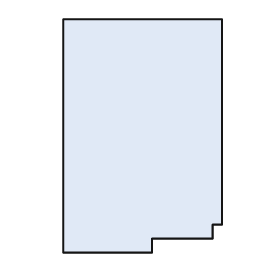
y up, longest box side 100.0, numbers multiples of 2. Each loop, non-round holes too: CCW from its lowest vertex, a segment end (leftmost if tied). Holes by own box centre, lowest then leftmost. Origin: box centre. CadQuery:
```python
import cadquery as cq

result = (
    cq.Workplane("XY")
    .moveTo(-34.0, -50.0)
    .lineTo(4.0, -50.0)
    .lineTo(4.0, -44.0)
    .lineTo(30.0, -44.0)
    .lineTo(30.0, -38.0)
    .lineTo(34.0, -38.0)
    .lineTo(34.0, 50.0)
    .lineTo(-34.0, 50.0)
    .close()
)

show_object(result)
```